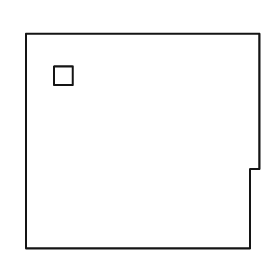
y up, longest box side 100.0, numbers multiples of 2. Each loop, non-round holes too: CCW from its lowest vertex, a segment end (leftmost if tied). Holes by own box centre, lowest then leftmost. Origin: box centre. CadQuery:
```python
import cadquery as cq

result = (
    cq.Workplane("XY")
    .moveTo(-50.0, -46.0)
    .lineTo(46.0, -46.0)
    .lineTo(46.0, -12.0)
    .lineTo(50.0, -12.0)
    .lineTo(50.0, 46.0)
    .lineTo(-50.0, 46.0)
    .close()
    .moveTo(-38.0, 24.0)
    .lineTo(-30.0, 24.0)
    .lineTo(-30.0, 32.0)
    .lineTo(-38.0, 32.0)
    .close()
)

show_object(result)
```